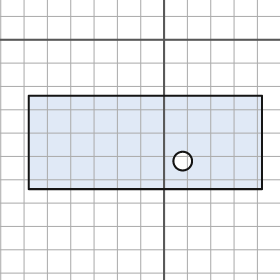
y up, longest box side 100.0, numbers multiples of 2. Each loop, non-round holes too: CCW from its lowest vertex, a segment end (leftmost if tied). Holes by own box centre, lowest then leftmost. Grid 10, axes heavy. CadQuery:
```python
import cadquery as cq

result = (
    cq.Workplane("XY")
    .moveTo(-58.0, -64.0)
    .lineTo(42.0, -64.0)
    .lineTo(42.0, -24.0)
    .lineTo(-58.0, -24.0)
    .close()
    .moveTo(8.0, -52.0)
    .circle(4.0)
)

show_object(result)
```